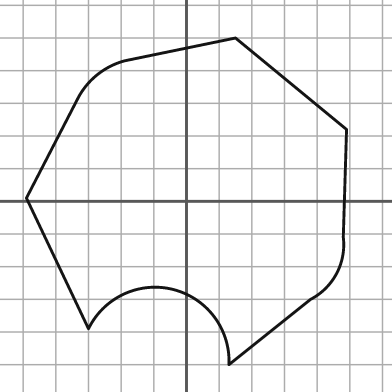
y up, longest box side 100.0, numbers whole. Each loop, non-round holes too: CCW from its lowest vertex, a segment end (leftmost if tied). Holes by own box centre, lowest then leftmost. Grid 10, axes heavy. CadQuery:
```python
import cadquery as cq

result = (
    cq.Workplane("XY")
    .moveTo(13.0, -50.0)
    .lineTo(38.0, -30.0)
    .threePointArc((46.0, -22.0), (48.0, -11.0))
    .lineTo(49.0, 22.0)
    .lineTo(15.0, 50.0)
    .lineTo(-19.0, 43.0)
    .threePointArc((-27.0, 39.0), (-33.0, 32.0))
    .lineTo(-49.0, 1.0)
    .lineTo(-30.0, -39.0)
    .threePointArc((-4.0, -27.0), (13.0, -50.0))
    .close()
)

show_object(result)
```